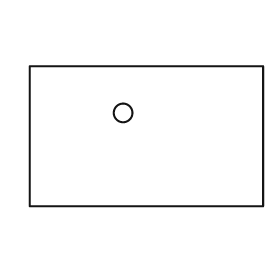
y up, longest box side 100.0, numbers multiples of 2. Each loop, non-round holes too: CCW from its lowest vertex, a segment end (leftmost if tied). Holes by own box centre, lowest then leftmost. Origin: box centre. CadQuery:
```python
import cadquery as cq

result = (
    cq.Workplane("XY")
    .moveTo(-50.0, -30.0)
    .lineTo(50.0, -30.0)
    .lineTo(50.0, 30.0)
    .lineTo(-50.0, 30.0)
    .close()
    .moveTo(-10.0, 10.0)
    .circle(4.0)
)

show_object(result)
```